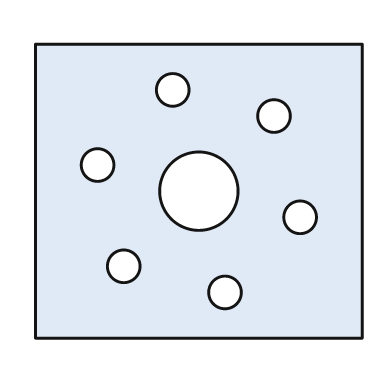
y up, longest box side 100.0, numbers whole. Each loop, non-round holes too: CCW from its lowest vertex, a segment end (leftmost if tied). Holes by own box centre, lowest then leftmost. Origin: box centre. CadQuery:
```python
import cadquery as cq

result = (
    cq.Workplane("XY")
    .moveTo(-50.0, -45.0)
    .lineTo(50.0, -45.0)
    .lineTo(50.0, 45.0)
    .lineTo(-50.0, 45.0)
    .close()
    .moveTo(8.0, -31.0)
    .circle(5.0)
    .moveTo(-23.0, -23.0)
    .circle(5.0)
    .moveTo(31.0, -8.0)
    .circle(5.0)
    .moveTo(0.0, 0.0)
    .circle(12.0)
    .moveTo(-31.0, 8.0)
    .circle(5.0)
    .moveTo(23.0, 23.0)
    .circle(5.0)
    .moveTo(-8.0, 31.0)
    .circle(5.0)
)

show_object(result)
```